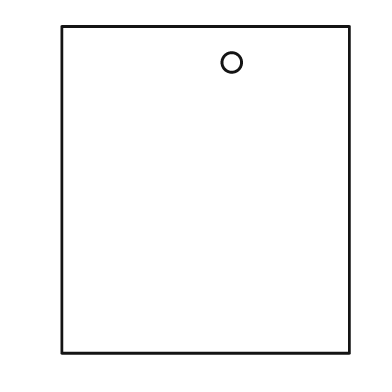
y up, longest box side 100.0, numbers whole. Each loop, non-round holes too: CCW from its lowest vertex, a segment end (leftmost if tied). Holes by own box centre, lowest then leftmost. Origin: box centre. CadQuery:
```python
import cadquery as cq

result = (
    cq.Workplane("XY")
    .moveTo(-44.0, -50.0)
    .lineTo(44.0, -50.0)
    .lineTo(44.0, 50.0)
    .lineTo(-44.0, 50.0)
    .close()
    .moveTo(8.0, 39.0)
    .circle(3.0)
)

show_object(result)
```